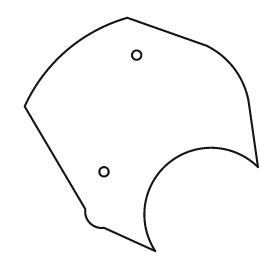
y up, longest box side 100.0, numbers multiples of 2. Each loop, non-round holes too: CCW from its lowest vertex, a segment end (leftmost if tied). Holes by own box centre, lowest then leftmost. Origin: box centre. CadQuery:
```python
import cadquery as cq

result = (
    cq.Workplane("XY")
    .moveTo(6.0, -50.0)
    .threePointArc((12.0, -12.0), (50.0, -14.0))
    .lineTo(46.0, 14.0)
    .threePointArc((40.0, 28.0), (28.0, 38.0))
    .lineTo(-6.0, 50.0)
    .threePointArc((-32.0, 36.0), (-50.0, 12.0))
    .lineTo(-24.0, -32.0)
    .threePointArc((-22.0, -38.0), (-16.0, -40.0))
    .close()
    .moveTo(-16.0, -16.0)
    .circle(2.0)
    .moveTo(-2.0, 34.0)
    .circle(2.0)
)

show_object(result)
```